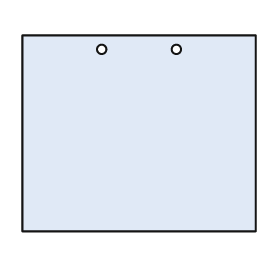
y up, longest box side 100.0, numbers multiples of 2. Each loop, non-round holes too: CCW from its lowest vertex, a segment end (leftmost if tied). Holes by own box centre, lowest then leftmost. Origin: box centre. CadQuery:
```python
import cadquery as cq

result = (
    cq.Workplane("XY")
    .moveTo(-50.0, -42.0)
    .lineTo(50.0, -42.0)
    .lineTo(50.0, 42.0)
    .lineTo(-50.0, 42.0)
    .close()
    .moveTo(-16.0, 36.0)
    .circle(2.0)
    .moveTo(16.0, 36.0)
    .circle(2.0)
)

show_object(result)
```